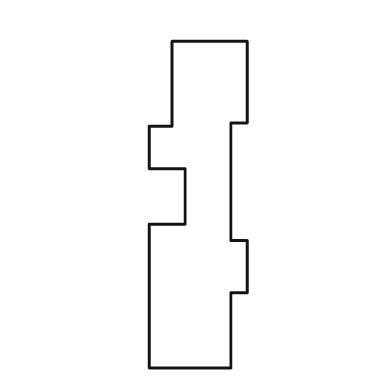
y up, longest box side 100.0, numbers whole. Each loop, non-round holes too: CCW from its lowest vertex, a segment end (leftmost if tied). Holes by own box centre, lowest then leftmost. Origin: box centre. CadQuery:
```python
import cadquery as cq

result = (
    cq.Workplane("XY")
    .moveTo(-15.0, -50.0)
    .lineTo(10.0, -50.0)
    .lineTo(10.0, -27.0)
    .lineTo(15.0, -27.0)
    .lineTo(15.0, -11.0)
    .lineTo(10.0, -11.0)
    .lineTo(10.0, 25.0)
    .lineTo(15.0, 25.0)
    .lineTo(15.0, 50.0)
    .lineTo(-8.0, 50.0)
    .lineTo(-8.0, 24.0)
    .lineTo(-15.0, 24.0)
    .lineTo(-15.0, 11.0)
    .lineTo(-4.0, 11.0)
    .lineTo(-4.0, -6.0)
    .lineTo(-15.0, -6.0)
    .close()
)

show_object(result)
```